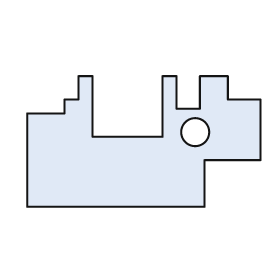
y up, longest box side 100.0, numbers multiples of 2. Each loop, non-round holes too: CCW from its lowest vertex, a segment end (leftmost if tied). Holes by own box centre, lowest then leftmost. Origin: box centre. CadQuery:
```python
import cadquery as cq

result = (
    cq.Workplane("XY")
    .moveTo(-50.0, -28.0)
    .lineTo(26.0, -28.0)
    .lineTo(26.0, -8.0)
    .lineTo(50.0, -8.0)
    .lineTo(50.0, 18.0)
    .lineTo(36.0, 18.0)
    .lineTo(36.0, 28.0)
    .lineTo(24.0, 28.0)
    .lineTo(24.0, 14.0)
    .lineTo(14.0, 14.0)
    .lineTo(14.0, 28.0)
    .lineTo(8.0, 28.0)
    .lineTo(8.0, 2.0)
    .lineTo(-22.0, 2.0)
    .lineTo(-22.0, 28.0)
    .lineTo(-28.0, 28.0)
    .lineTo(-28.0, 18.0)
    .lineTo(-34.0, 18.0)
    .lineTo(-34.0, 12.0)
    .lineTo(-50.0, 12.0)
    .close()
    .moveTo(22.0, 4.0)
    .circle(6.0)
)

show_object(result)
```